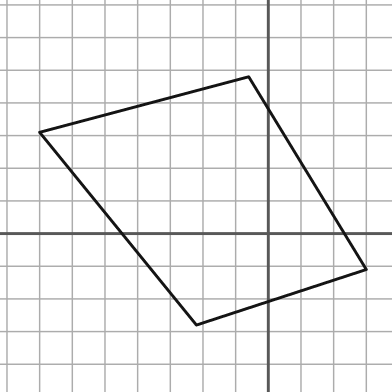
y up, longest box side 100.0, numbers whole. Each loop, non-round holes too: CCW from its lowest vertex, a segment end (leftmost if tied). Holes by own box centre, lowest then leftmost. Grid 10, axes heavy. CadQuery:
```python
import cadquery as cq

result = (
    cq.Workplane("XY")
    .moveTo(-22.0, -28.0)
    .lineTo(30.0, -11.0)
    .lineTo(-6.0, 48.0)
    .lineTo(-70.0, 31.0)
    .close()
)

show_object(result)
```